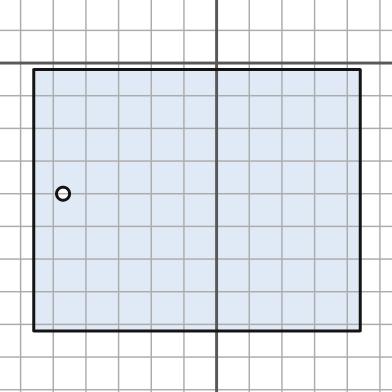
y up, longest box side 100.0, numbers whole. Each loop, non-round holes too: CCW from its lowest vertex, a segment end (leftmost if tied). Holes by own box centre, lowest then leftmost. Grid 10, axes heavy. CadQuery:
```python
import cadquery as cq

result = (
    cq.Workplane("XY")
    .moveTo(-56.0, -82.0)
    .lineTo(44.0, -82.0)
    .lineTo(44.0, -2.0)
    .lineTo(-56.0, -2.0)
    .close()
    .moveTo(-47.0, -40.0)
    .circle(2.0)
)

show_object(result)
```